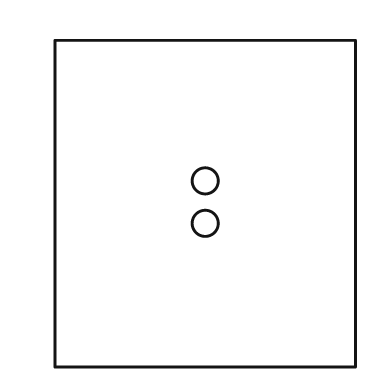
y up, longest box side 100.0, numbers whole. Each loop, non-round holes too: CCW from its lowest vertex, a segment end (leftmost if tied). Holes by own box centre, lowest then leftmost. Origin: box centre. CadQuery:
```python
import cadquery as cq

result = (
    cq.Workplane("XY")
    .moveTo(-46.0, -50.0)
    .lineTo(46.0, -50.0)
    .lineTo(46.0, 50.0)
    .lineTo(-46.0, 50.0)
    .close()
    .moveTo(0.0, -6.0)
    .circle(4.0)
    .moveTo(0.0, 7.0)
    .circle(4.0)
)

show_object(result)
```